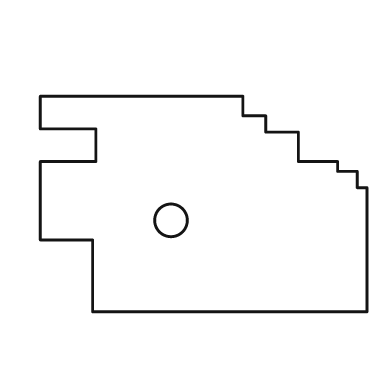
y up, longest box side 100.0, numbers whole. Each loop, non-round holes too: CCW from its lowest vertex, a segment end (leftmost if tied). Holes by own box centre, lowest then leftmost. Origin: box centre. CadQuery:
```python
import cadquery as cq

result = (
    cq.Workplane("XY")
    .moveTo(-34.0, -33.0)
    .lineTo(50.0, -33.0)
    .lineTo(50.0, 5.0)
    .lineTo(47.0, 5.0)
    .lineTo(47.0, 10.0)
    .lineTo(41.0, 10.0)
    .lineTo(41.0, 13.0)
    .lineTo(29.0, 13.0)
    .lineTo(29.0, 22.0)
    .lineTo(19.0, 22.0)
    .lineTo(19.0, 27.0)
    .lineTo(12.0, 27.0)
    .lineTo(12.0, 33.0)
    .lineTo(-50.0, 33.0)
    .lineTo(-50.0, 23.0)
    .lineTo(-33.0, 23.0)
    .lineTo(-33.0, 13.0)
    .lineTo(-50.0, 13.0)
    .lineTo(-50.0, -11.0)
    .lineTo(-34.0, -11.0)
    .close()
    .moveTo(-10.0, -5.0)
    .circle(5.0)
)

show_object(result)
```